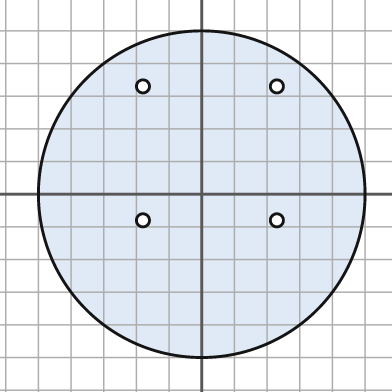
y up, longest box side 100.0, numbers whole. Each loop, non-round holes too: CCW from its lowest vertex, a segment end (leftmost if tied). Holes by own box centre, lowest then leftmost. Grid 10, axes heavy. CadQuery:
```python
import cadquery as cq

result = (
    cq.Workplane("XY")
    .moveTo(0.0, 0.0)
    .circle(50.0)
    .moveTo(-18.0, -8.0)
    .circle(2.0)
    .moveTo(23.0, -8.0)
    .circle(2.0)
    .moveTo(-18.0, 33.0)
    .circle(2.0)
    .moveTo(23.0, 33.0)
    .circle(2.0)
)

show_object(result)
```